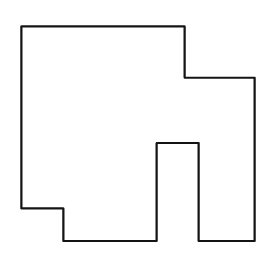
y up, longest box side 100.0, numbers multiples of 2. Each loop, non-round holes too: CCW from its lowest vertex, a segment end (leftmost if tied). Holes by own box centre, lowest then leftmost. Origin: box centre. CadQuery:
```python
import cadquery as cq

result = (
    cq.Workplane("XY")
    .moveTo(-32.0, -46.0)
    .lineTo(8.0, -46.0)
    .lineTo(8.0, -4.0)
    .lineTo(26.0, -4.0)
    .lineTo(26.0, -46.0)
    .lineTo(50.0, -46.0)
    .lineTo(50.0, 24.0)
    .lineTo(20.0, 24.0)
    .lineTo(20.0, 46.0)
    .lineTo(-50.0, 46.0)
    .lineTo(-50.0, -32.0)
    .lineTo(-32.0, -32.0)
    .close()
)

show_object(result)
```